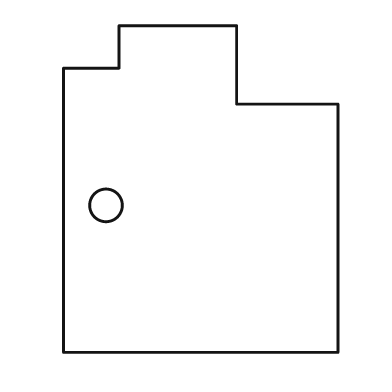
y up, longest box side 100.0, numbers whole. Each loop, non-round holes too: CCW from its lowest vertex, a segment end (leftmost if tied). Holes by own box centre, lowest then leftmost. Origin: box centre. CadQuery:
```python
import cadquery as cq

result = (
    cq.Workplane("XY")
    .moveTo(-42.0, -50.0)
    .lineTo(42.0, -50.0)
    .lineTo(42.0, 26.0)
    .lineTo(11.0, 26.0)
    .lineTo(11.0, 50.0)
    .lineTo(-25.0, 50.0)
    .lineTo(-25.0, 37.0)
    .lineTo(-42.0, 37.0)
    .close()
    .moveTo(-29.0, -5.0)
    .circle(5.0)
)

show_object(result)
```